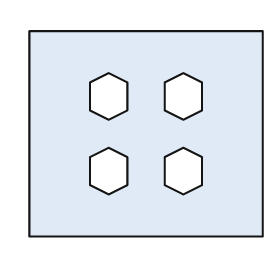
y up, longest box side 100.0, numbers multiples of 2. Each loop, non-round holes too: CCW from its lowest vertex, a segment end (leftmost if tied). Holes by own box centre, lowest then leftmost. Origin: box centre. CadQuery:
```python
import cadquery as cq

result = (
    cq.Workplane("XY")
    .moveTo(-50.0, -44.0)
    .lineTo(50.0, -44.0)
    .lineTo(50.0, 44.0)
    .lineTo(-50.0, 44.0)
    .close()
    .moveTo(-16.0, -26.0)
    .lineTo(-8.0, -22.0)
    .lineTo(-8.0, -10.0)
    .lineTo(-16.0, -6.0)
    .lineTo(-24.0, -10.0)
    .lineTo(-24.0, -22.0)
    .close()
    .moveTo(16.0, -26.0)
    .lineTo(24.0, -22.0)
    .lineTo(24.0, -10.0)
    .lineTo(16.0, -6.0)
    .lineTo(8.0, -10.0)
    .lineTo(8.0, -22.0)
    .close()
    .moveTo(-16.0, 6.0)
    .lineTo(-8.0, 10.0)
    .lineTo(-8.0, 22.0)
    .lineTo(-16.0, 26.0)
    .lineTo(-24.0, 22.0)
    .lineTo(-24.0, 10.0)
    .close()
    .moveTo(16.0, 6.0)
    .lineTo(24.0, 10.0)
    .lineTo(24.0, 22.0)
    .lineTo(16.0, 26.0)
    .lineTo(8.0, 22.0)
    .lineTo(8.0, 10.0)
    .close()
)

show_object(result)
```